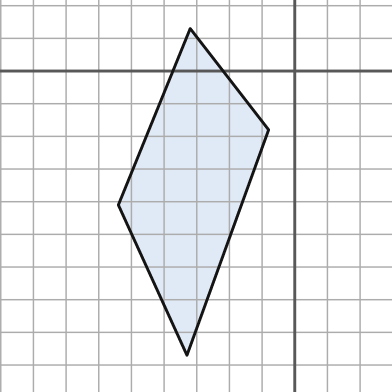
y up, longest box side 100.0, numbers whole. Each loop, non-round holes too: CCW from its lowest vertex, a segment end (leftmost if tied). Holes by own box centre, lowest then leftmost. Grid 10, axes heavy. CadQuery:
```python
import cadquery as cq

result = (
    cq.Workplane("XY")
    .moveTo(-33.0, -87.0)
    .lineTo(-8.0, -18.0)
    .lineTo(-32.0, 13.0)
    .lineTo(-54.0, -41.0)
    .close()
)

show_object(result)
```